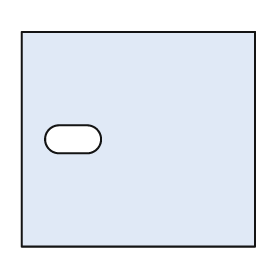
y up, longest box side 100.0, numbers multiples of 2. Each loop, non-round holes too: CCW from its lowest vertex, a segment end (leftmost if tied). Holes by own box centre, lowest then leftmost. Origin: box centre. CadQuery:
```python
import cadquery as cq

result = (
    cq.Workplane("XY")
    .moveTo(-50.0, -46.0)
    .lineTo(50.0, -46.0)
    .lineTo(50.0, 46.0)
    .lineTo(-50.0, 46.0)
    .close()
    .moveTo(-34.0, -6.0)
    .lineTo(-22.0, -6.0)
    .threePointArc((-16.0, 0.0), (-22.0, 6.0))
    .lineTo(-34.0, 6.0)
    .threePointArc((-40.0, 0.0), (-34.0, -6.0))
    .close()
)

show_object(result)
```